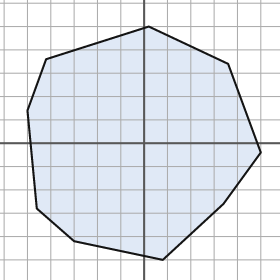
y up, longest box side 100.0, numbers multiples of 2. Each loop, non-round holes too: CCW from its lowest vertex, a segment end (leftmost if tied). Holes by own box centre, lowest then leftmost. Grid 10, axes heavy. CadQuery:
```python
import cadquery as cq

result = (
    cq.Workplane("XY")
    .moveTo(8.0, -50.0)
    .lineTo(34.0, -26.0)
    .lineTo(50.0, -4.0)
    .lineTo(36.0, 34.0)
    .lineTo(2.0, 50.0)
    .lineTo(-42.0, 36.0)
    .lineTo(-50.0, 14.0)
    .lineTo(-46.0, -28.0)
    .lineTo(-30.0, -42.0)
    .close()
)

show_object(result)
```